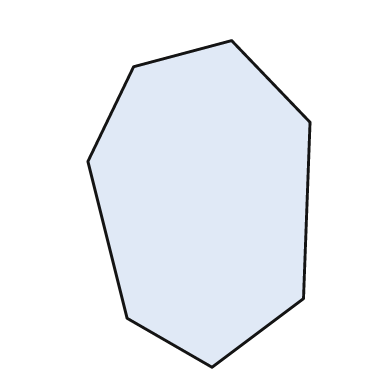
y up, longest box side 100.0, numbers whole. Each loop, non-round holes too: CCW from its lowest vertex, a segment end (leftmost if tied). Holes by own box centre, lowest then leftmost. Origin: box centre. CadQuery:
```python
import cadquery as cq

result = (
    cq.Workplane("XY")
    .moveTo(4.0, -50.0)
    .lineTo(32.0, -29.0)
    .lineTo(34.0, 25.0)
    .lineTo(10.0, 50.0)
    .lineTo(-20.0, 42.0)
    .lineTo(-34.0, 13.0)
    .lineTo(-22.0, -35.0)
    .close()
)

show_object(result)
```